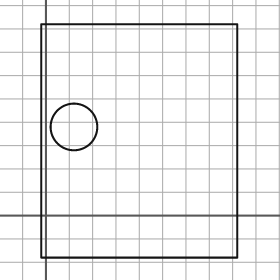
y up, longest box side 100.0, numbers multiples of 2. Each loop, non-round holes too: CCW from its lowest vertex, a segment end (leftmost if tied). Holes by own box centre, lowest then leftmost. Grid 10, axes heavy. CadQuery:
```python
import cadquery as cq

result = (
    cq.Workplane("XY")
    .moveTo(-2.0, -18.0)
    .lineTo(82.0, -18.0)
    .lineTo(82.0, 82.0)
    .lineTo(-2.0, 82.0)
    .close()
    .moveTo(12.0, 38.0)
    .circle(10.0)
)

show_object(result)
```